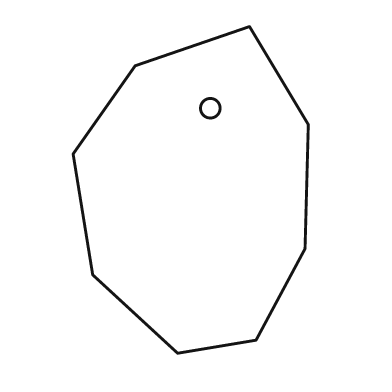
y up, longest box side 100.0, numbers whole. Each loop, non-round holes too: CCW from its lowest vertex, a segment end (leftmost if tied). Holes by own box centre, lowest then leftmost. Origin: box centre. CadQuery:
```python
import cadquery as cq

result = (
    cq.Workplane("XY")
    .moveTo(-4.0, -50.0)
    .lineTo(20.0, -46.0)
    .lineTo(35.0, -18.0)
    .lineTo(36.0, 20.0)
    .lineTo(18.0, 50.0)
    .lineTo(-17.0, 38.0)
    .lineTo(-36.0, 11.0)
    .lineTo(-30.0, -26.0)
    .close()
    .moveTo(6.0, 25.0)
    .circle(3.0)
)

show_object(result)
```